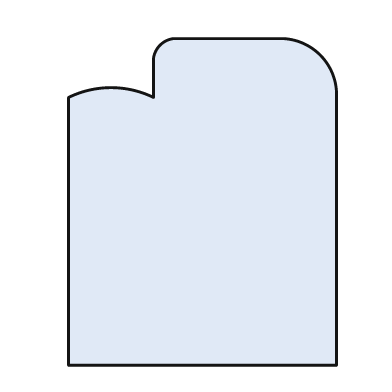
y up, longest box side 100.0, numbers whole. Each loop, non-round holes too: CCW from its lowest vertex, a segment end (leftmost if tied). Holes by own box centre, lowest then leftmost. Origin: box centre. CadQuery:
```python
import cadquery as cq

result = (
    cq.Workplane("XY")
    .moveTo(-41.0, -50.0)
    .lineTo(41.0, -50.0)
    .lineTo(41.0, 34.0)
    .threePointArc((36.0, 45.0), (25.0, 50.0))
    .lineTo(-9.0, 50.0)
    .threePointArc((-13.0, 48.0), (-15.0, 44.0))
    .lineTo(-15.0, 32.0)
    .threePointArc((-28.0, 35.0), (-41.0, 32.0))
    .close()
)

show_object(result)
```